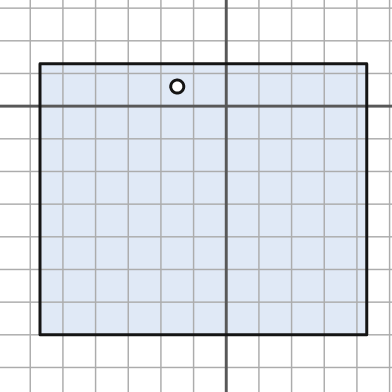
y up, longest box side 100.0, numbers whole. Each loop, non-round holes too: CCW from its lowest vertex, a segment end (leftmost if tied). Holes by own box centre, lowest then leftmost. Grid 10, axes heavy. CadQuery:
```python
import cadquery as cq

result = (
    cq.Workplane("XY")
    .moveTo(-57.0, -70.0)
    .lineTo(43.0, -70.0)
    .lineTo(43.0, 13.0)
    .lineTo(-57.0, 13.0)
    .close()
    .moveTo(-15.0, 6.0)
    .circle(2.0)
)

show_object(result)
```